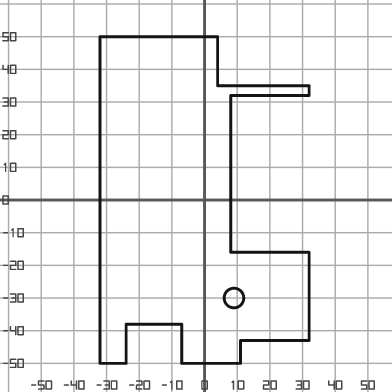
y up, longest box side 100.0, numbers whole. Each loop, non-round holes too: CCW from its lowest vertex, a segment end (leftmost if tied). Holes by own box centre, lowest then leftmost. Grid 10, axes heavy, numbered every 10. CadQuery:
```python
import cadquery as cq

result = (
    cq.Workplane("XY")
    .moveTo(-32.0, -50.0)
    .lineTo(-24.0, -50.0)
    .lineTo(-24.0, -38.0)
    .lineTo(-7.0, -38.0)
    .lineTo(-7.0, -50.0)
    .lineTo(11.0, -50.0)
    .lineTo(11.0, -43.0)
    .lineTo(32.0, -43.0)
    .lineTo(32.0, -16.0)
    .lineTo(8.0, -16.0)
    .lineTo(8.0, 32.0)
    .lineTo(32.0, 32.0)
    .lineTo(32.0, 35.0)
    .lineTo(4.0, 35.0)
    .lineTo(4.0, 50.0)
    .lineTo(-32.0, 50.0)
    .close()
    .moveTo(9.0, -30.0)
    .circle(3.0)
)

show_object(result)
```